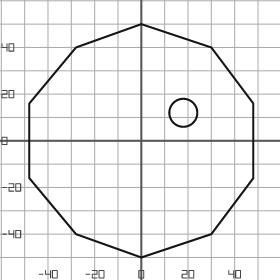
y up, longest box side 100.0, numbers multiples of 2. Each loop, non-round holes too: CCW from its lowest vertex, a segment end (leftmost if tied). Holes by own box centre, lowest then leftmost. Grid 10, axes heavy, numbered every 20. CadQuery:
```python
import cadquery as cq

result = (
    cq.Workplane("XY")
    .moveTo(0.0, -50.0)
    .lineTo(30.0, -40.0)
    .lineTo(48.0, -16.0)
    .lineTo(48.0, 16.0)
    .lineTo(30.0, 40.0)
    .lineTo(0.0, 50.0)
    .lineTo(-28.0, 40.0)
    .lineTo(-48.0, 16.0)
    .lineTo(-48.0, -16.0)
    .lineTo(-28.0, -40.0)
    .close()
    .moveTo(18.0, 12.0)
    .circle(6.0)
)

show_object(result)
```